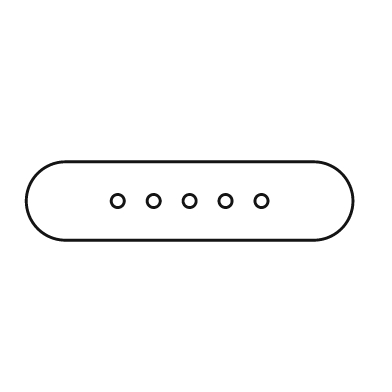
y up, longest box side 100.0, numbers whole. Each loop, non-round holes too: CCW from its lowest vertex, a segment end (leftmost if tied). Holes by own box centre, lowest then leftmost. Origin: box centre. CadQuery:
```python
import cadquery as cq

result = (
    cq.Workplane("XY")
    .moveTo(-38.0, -12.0)
    .lineTo(38.0, -12.0)
    .threePointArc((50.0, 0.0), (38.0, 12.0))
    .lineTo(-38.0, 12.0)
    .threePointArc((-50.0, 0.0), (-38.0, -12.0))
    .close()
    .moveTo(-22.0, 0.0)
    .circle(2.0)
    .moveTo(-11.0, 0.0)
    .circle(2.0)
    .moveTo(0.0, 0.0)
    .circle(2.0)
    .moveTo(11.0, 0.0)
    .circle(2.0)
    .moveTo(22.0, 0.0)
    .circle(2.0)
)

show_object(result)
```